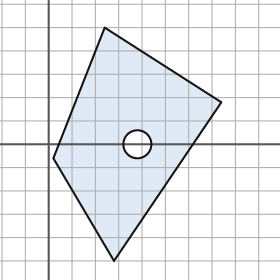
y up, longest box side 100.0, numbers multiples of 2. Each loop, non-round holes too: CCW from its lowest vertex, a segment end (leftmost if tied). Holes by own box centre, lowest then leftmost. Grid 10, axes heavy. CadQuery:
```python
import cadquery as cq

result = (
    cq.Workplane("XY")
    .moveTo(28.0, -50.0)
    .lineTo(74.0, 18.0)
    .lineTo(24.0, 50.0)
    .lineTo(2.0, -6.0)
    .close()
    .moveTo(38.0, 0.0)
    .circle(6.0)
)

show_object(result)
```